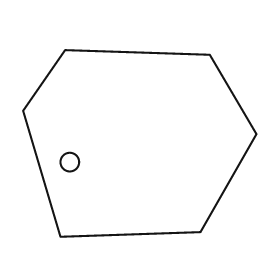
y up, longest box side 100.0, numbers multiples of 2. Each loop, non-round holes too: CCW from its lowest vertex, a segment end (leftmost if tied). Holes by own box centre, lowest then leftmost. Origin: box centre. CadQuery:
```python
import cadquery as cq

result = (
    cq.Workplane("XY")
    .moveTo(-34.0, -40.0)
    .lineTo(26.0, -38.0)
    .lineTo(50.0, 4.0)
    .lineTo(30.0, 38.0)
    .lineTo(-32.0, 40.0)
    .lineTo(-50.0, 14.0)
    .close()
    .moveTo(-30.0, -8.0)
    .circle(4.0)
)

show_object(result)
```